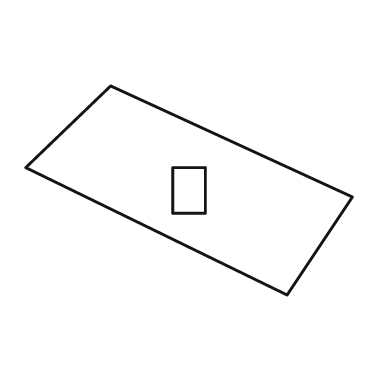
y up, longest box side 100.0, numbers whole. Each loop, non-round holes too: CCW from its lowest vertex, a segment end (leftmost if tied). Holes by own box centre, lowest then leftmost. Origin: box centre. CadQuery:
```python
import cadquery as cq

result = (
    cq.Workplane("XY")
    .moveTo(30.0, -32.0)
    .lineTo(50.0, -2.0)
    .lineTo(-24.0, 32.0)
    .lineTo(-50.0, 7.0)
    .close()
    .moveTo(-5.0, -7.0)
    .lineTo(5.0, -7.0)
    .lineTo(5.0, 7.0)
    .lineTo(-5.0, 7.0)
    .close()
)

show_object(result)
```